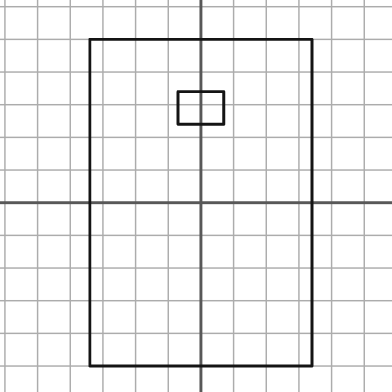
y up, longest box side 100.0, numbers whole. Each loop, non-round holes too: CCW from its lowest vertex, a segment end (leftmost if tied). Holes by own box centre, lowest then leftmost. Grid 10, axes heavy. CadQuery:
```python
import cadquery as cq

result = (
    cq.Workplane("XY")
    .moveTo(-34.0, -50.0)
    .lineTo(34.0, -50.0)
    .lineTo(34.0, 50.0)
    .lineTo(-34.0, 50.0)
    .close()
    .moveTo(-7.0, 24.0)
    .lineTo(7.0, 24.0)
    .lineTo(7.0, 34.0)
    .lineTo(-7.0, 34.0)
    .close()
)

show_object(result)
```